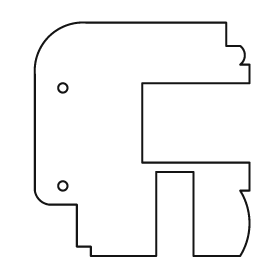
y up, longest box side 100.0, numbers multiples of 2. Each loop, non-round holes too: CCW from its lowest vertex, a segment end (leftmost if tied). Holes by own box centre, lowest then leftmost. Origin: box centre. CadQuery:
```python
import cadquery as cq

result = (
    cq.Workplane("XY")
    .moveTo(-22.0, -50.0)
    .lineTo(6.0, -50.0)
    .lineTo(6.0, -14.0)
    .lineTo(22.0, -14.0)
    .lineTo(22.0, -50.0)
    .lineTo(42.0, -50.0)
    .threePointArc((46.0, -36.0), (42.0, -22.0))
    .lineTo(46.0, -22.0)
    .lineTo(46.0, -10.0)
    .lineTo(0.0, -10.0)
    .lineTo(0.0, 24.0)
    .lineTo(46.0, 24.0)
    .lineTo(46.0, 32.0)
    .lineTo(42.0, 32.0)
    .threePointArc((44.0, 36.0), (42.0, 40.0))
    .lineTo(36.0, 40.0)
    .lineTo(36.0, 50.0)
    .lineTo(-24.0, 50.0)
    .threePointArc((-40.0, 44.0), (-46.0, 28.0))
    .lineTo(-46.0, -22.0)
    .threePointArc((-44.0, -26.0), (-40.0, -28.0))
    .lineTo(-28.0, -28.0)
    .lineTo(-28.0, -46.0)
    .lineTo(-22.0, -46.0)
    .close()
    .moveTo(-34.0, -20.0)
    .circle(2.0)
    .moveTo(-34.0, 22.0)
    .circle(2.0)
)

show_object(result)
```